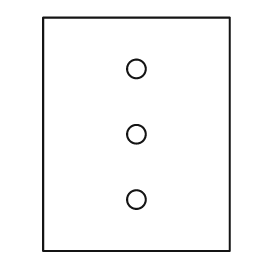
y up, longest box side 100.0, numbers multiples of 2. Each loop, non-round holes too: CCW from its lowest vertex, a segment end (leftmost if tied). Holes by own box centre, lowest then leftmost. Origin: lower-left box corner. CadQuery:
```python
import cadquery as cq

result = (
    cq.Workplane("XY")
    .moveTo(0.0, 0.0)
    .lineTo(80.0, 0.0)
    .lineTo(80.0, 100.0)
    .lineTo(0.0, 100.0)
    .close()
    .moveTo(40.0, 22.0)
    .circle(4.0)
    .moveTo(40.0, 50.0)
    .circle(4.0)
    .moveTo(40.0, 78.0)
    .circle(4.0)
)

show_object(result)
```